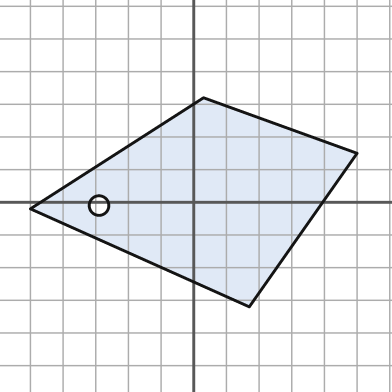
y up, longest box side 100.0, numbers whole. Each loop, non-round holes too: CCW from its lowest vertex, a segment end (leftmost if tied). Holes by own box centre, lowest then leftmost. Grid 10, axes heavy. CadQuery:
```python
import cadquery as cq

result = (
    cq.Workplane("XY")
    .moveTo(17.0, -32.0)
    .lineTo(50.0, 15.0)
    .lineTo(3.0, 32.0)
    .lineTo(-50.0, -2.0)
    .close()
    .moveTo(-29.0, -1.0)
    .circle(3.0)
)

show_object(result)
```